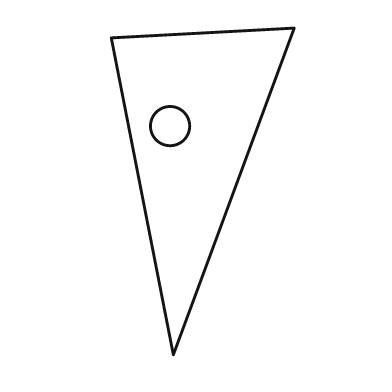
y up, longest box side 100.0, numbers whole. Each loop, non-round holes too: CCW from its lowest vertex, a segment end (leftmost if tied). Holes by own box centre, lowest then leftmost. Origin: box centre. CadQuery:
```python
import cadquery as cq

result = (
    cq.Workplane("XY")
    .moveTo(-9.0, -50.0)
    .lineTo(28.0, 50.0)
    .lineTo(-28.0, 47.0)
    .close()
    .moveTo(-10.0, 20.0)
    .circle(6.0)
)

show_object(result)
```